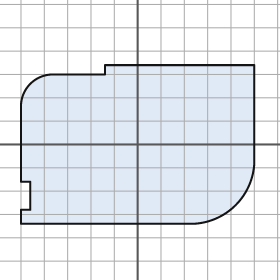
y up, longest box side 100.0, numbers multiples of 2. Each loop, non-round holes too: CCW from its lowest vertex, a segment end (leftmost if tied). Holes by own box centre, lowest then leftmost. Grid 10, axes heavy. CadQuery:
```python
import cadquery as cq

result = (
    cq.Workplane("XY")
    .moveTo(-50.0, -34.0)
    .lineTo(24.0, -34.0)
    .threePointArc((42.0, -26.0), (50.0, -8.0))
    .lineTo(50.0, 34.0)
    .lineTo(-14.0, 34.0)
    .lineTo(-14.0, 30.0)
    .lineTo(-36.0, 30.0)
    .threePointArc((-46.0, 26.0), (-50.0, 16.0))
    .lineTo(-50.0, -16.0)
    .lineTo(-46.0, -16.0)
    .lineTo(-46.0, -28.0)
    .lineTo(-50.0, -28.0)
    .close()
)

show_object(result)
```